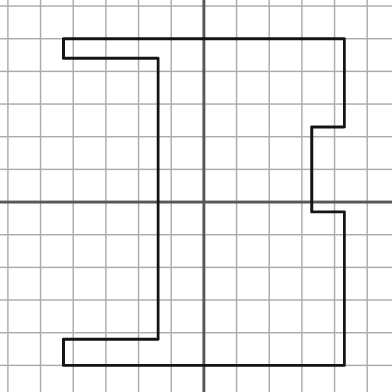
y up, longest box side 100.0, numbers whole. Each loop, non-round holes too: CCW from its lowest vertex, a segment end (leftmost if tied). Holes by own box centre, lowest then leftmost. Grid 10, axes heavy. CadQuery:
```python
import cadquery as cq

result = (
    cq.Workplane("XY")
    .moveTo(-43.0, -50.0)
    .lineTo(43.0, -50.0)
    .lineTo(43.0, -3.0)
    .lineTo(33.0, -3.0)
    .lineTo(33.0, 23.0)
    .lineTo(43.0, 23.0)
    .lineTo(43.0, 50.0)
    .lineTo(-43.0, 50.0)
    .lineTo(-43.0, 44.0)
    .lineTo(-14.0, 44.0)
    .lineTo(-14.0, -42.0)
    .lineTo(-43.0, -42.0)
    .close()
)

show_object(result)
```